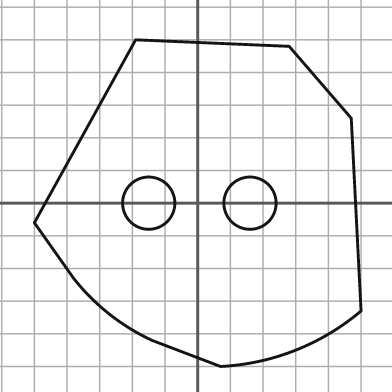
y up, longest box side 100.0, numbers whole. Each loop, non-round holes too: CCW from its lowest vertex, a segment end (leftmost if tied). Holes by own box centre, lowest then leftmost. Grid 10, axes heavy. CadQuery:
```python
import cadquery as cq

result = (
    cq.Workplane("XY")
    .moveTo(7.0, -50.0)
    .threePointArc((30.0, -45.0), (50.0, -33.0))
    .lineTo(47.0, 26.0)
    .lineTo(28.0, 48.0)
    .lineTo(-19.0, 50.0)
    .lineTo(-50.0, -6.0)
    .lineTo(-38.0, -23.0)
    .threePointArc((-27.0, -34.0), (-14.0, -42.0))
    .close()
    .moveTo(-15.0, 0.0)
    .circle(8.0)
    .moveTo(16.0, 0.0)
    .circle(8.0)
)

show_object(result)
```